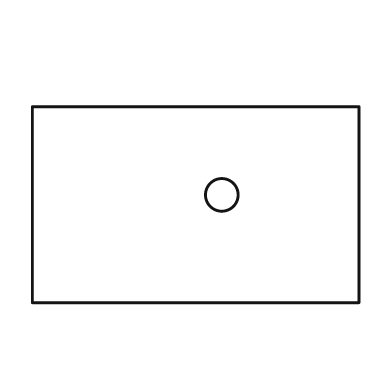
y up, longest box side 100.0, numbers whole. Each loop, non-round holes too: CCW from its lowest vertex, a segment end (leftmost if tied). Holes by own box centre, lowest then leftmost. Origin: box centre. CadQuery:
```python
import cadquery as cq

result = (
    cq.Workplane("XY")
    .moveTo(-50.0, -30.0)
    .lineTo(50.0, -30.0)
    .lineTo(50.0, 30.0)
    .lineTo(-50.0, 30.0)
    .close()
    .moveTo(8.0, 3.0)
    .circle(5.0)
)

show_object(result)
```